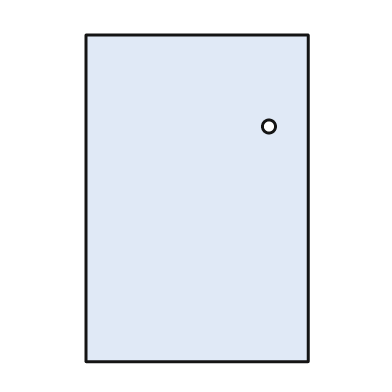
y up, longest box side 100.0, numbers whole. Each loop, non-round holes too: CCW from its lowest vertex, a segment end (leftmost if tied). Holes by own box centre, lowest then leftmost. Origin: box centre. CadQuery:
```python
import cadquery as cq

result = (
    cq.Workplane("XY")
    .moveTo(-34.0, -50.0)
    .lineTo(34.0, -50.0)
    .lineTo(34.0, 50.0)
    .lineTo(-34.0, 50.0)
    .close()
    .moveTo(22.0, 22.0)
    .circle(2.0)
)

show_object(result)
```